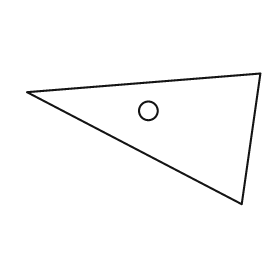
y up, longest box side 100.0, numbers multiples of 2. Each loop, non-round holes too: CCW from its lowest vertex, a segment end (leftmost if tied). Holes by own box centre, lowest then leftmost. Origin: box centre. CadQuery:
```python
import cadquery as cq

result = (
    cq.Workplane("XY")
    .moveTo(42.0, -28.0)
    .lineTo(50.0, 28.0)
    .lineTo(-50.0, 20.0)
    .close()
    .moveTo(2.0, 12.0)
    .circle(4.0)
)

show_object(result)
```